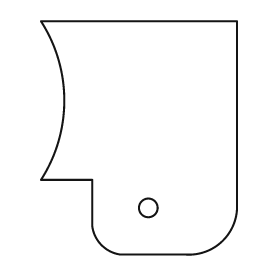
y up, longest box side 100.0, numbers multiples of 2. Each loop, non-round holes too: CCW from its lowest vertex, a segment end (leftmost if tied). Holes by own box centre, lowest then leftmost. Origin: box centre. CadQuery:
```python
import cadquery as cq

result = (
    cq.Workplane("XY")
    .moveTo(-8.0, -50.0)
    .lineTo(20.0, -50.0)
    .threePointArc((36.0, -44.0), (42.0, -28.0))
    .lineTo(42.0, 50.0)
    .lineTo(-42.0, 50.0)
    .threePointArc((-32.0, 16.0), (-42.0, -18.0))
    .lineTo(-20.0, -18.0)
    .lineTo(-20.0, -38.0)
    .threePointArc((-16.0, -46.0), (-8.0, -50.0))
    .close()
    .moveTo(4.0, -30.0)
    .circle(4.0)
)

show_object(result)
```